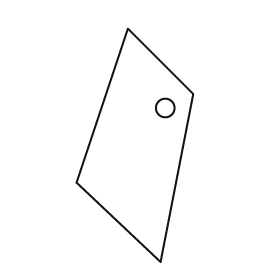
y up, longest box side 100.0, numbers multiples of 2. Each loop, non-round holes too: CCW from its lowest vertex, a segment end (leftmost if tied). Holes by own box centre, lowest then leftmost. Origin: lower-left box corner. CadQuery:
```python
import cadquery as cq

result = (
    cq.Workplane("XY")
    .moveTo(36.0, 0.0)
    .lineTo(50.0, 72.0)
    .lineTo(22.0, 100.0)
    .lineTo(0.0, 34.0)
    .close()
    .moveTo(38.0, 66.0)
    .circle(4.0)
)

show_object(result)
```